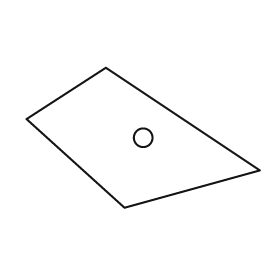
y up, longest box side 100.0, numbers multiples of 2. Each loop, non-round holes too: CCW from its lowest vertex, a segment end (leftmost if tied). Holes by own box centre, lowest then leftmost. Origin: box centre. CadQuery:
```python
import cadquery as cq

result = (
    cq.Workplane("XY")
    .moveTo(-8.0, -30.0)
    .lineTo(50.0, -14.0)
    .lineTo(-16.0, 30.0)
    .lineTo(-50.0, 8.0)
    .close()
    .moveTo(0.0, 0.0)
    .circle(4.0)
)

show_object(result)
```